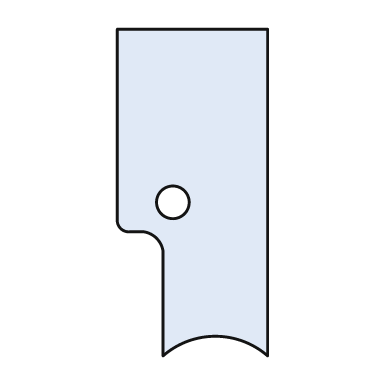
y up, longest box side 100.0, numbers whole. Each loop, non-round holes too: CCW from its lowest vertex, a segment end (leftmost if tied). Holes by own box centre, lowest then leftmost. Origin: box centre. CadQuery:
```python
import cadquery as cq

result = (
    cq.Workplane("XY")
    .moveTo(-9.0, -50.0)
    .threePointArc((7.0, -44.0), (23.0, -50.0))
    .lineTo(23.0, 50.0)
    .lineTo(-23.0, 50.0)
    .lineTo(-23.0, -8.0)
    .threePointArc((-22.0, -11.0), (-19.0, -12.0))
    .lineTo(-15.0, -12.0)
    .threePointArc((-11.0, -14.0), (-9.0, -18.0))
    .close()
    .moveTo(-6.0, -3.0)
    .circle(5.0)
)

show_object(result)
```